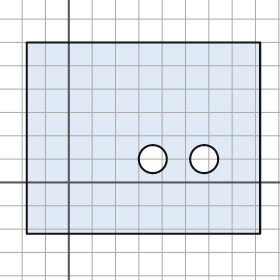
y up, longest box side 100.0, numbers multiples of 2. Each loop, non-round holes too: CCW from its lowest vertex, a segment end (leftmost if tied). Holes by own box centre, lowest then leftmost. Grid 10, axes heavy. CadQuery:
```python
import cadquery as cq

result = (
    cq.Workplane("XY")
    .moveTo(-18.0, -22.0)
    .lineTo(82.0, -22.0)
    .lineTo(82.0, 60.0)
    .lineTo(-18.0, 60.0)
    .close()
    .moveTo(36.0, 10.0)
    .circle(6.0)
    .moveTo(58.0, 10.0)
    .circle(6.0)
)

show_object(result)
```